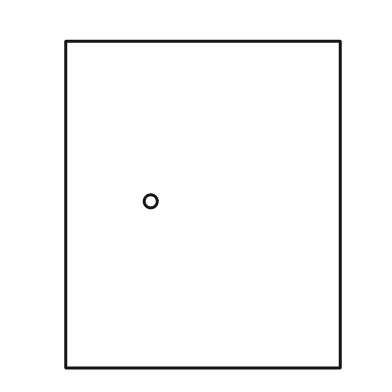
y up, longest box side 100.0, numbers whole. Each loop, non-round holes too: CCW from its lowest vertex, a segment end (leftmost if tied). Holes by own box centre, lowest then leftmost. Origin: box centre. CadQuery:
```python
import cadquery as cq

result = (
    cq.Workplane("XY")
    .moveTo(-42.0, -50.0)
    .lineTo(42.0, -50.0)
    .lineTo(42.0, 50.0)
    .lineTo(-42.0, 50.0)
    .close()
    .moveTo(-16.0, 1.0)
    .circle(2.0)
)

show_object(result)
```